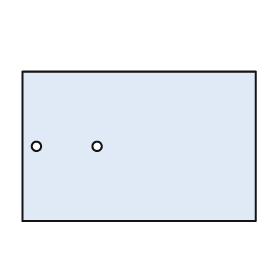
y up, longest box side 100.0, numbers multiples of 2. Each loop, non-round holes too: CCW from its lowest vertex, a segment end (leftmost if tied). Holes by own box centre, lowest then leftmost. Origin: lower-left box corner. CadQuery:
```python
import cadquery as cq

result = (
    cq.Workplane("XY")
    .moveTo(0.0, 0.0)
    .lineTo(100.0, 0.0)
    .lineTo(100.0, 64.0)
    .lineTo(0.0, 64.0)
    .close()
    .moveTo(6.0, 32.0)
    .circle(2.0)
    .moveTo(32.0, 32.0)
    .circle(2.0)
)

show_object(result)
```